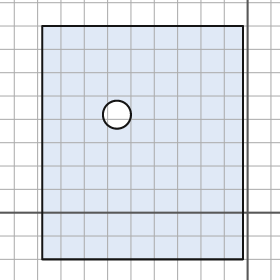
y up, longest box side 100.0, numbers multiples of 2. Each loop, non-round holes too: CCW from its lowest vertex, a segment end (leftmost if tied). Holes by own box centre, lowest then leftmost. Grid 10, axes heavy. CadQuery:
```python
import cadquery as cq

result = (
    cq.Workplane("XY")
    .moveTo(-88.0, -20.0)
    .lineTo(-2.0, -20.0)
    .lineTo(-2.0, 80.0)
    .lineTo(-88.0, 80.0)
    .close()
    .moveTo(-56.0, 42.0)
    .circle(6.0)
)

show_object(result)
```